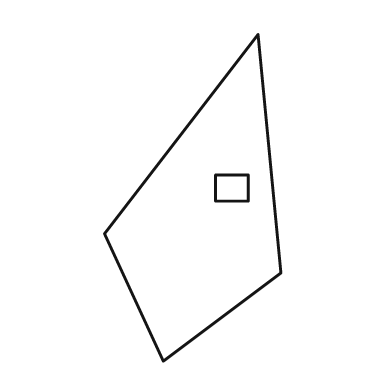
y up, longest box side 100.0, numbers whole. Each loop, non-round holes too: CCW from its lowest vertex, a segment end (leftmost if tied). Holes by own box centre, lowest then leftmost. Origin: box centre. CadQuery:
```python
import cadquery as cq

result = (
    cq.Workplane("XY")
    .moveTo(-9.0, -50.0)
    .lineTo(27.0, -23.0)
    .lineTo(20.0, 50.0)
    .lineTo(-27.0, -11.0)
    .close()
    .moveTo(7.0, -1.0)
    .lineTo(17.0, -1.0)
    .lineTo(17.0, 7.0)
    .lineTo(7.0, 7.0)
    .close()
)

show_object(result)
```